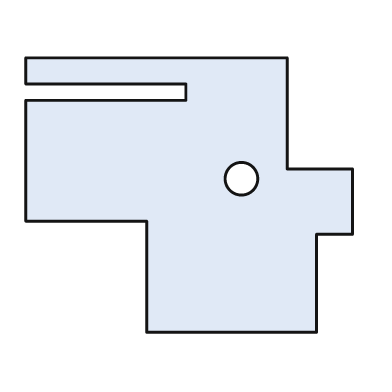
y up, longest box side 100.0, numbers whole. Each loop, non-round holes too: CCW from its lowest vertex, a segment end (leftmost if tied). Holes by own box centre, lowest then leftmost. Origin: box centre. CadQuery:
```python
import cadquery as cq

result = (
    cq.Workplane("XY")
    .moveTo(-13.0, -42.0)
    .lineTo(39.0, -42.0)
    .lineTo(39.0, -12.0)
    .lineTo(50.0, -12.0)
    .lineTo(50.0, 8.0)
    .lineTo(30.0, 8.0)
    .lineTo(30.0, 42.0)
    .lineTo(-50.0, 42.0)
    .lineTo(-50.0, 34.0)
    .lineTo(-1.0, 34.0)
    .lineTo(-1.0, 29.0)
    .lineTo(-50.0, 29.0)
    .lineTo(-50.0, -8.0)
    .lineTo(-13.0, -8.0)
    .close()
    .moveTo(16.0, 5.0)
    .circle(5.0)
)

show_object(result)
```